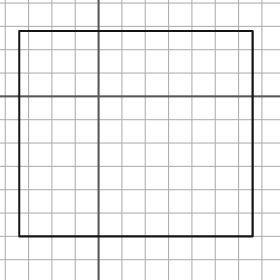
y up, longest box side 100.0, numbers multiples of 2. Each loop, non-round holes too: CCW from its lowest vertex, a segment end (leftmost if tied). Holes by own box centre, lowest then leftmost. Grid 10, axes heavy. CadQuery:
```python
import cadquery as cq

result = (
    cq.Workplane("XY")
    .moveTo(-34.0, -60.0)
    .lineTo(66.0, -60.0)
    .lineTo(66.0, 28.0)
    .lineTo(-34.0, 28.0)
    .close()
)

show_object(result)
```